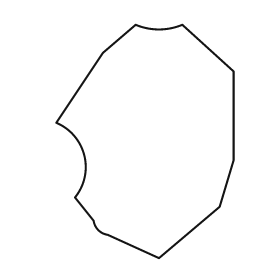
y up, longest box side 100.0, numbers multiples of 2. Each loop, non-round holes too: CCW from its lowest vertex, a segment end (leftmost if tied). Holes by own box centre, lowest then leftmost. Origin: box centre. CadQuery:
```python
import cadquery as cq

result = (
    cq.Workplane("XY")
    .moveTo(6.0, -50.0)
    .lineTo(32.0, -28.0)
    .lineTo(38.0, -8.0)
    .lineTo(38.0, 30.0)
    .lineTo(16.0, 50.0)
    .threePointArc((6.0, 48.0), (-4.0, 50.0))
    .lineTo(-18.0, 38.0)
    .lineTo(-38.0, 8.0)
    .threePointArc((-26.0, -6.0), (-30.0, -24.0))
    .lineTo(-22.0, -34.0)
    .threePointArc((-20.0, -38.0), (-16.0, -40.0))
    .close()
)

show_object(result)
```